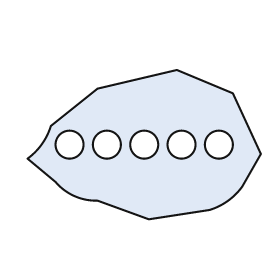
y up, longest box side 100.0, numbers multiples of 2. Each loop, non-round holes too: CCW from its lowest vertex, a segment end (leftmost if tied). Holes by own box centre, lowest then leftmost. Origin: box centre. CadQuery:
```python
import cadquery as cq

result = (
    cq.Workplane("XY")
    .moveTo(2.0, -32.0)
    .lineTo(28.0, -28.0)
    .threePointArc((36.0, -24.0), (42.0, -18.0))
    .lineTo(50.0, -4.0)
    .lineTo(38.0, 22.0)
    .lineTo(14.0, 32.0)
    .lineTo(-20.0, 24.0)
    .lineTo(-40.0, 8.0)
    .threePointArc((-44.0, 0.0), (-50.0, -6.0))
    .lineTo(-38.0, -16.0)
    .threePointArc((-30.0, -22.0), (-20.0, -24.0))
    .close()
    .moveTo(-32.0, 0.0)
    .circle(6.0)
    .moveTo(-16.0, 0.0)
    .circle(6.0)
    .moveTo(0.0, 0.0)
    .circle(6.0)
    .moveTo(16.0, 0.0)
    .circle(6.0)
    .moveTo(32.0, 0.0)
    .circle(6.0)
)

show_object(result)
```